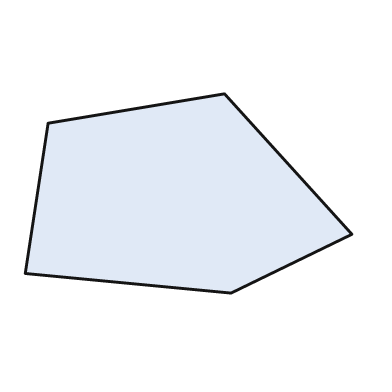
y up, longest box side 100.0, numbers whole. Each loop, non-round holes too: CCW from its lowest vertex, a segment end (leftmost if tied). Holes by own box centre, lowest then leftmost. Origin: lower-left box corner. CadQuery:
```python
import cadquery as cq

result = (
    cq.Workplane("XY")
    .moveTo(63.0, 0.0)
    .lineTo(100.0, 18.0)
    .lineTo(61.0, 61.0)
    .lineTo(7.0, 52.0)
    .lineTo(0.0, 6.0)
    .close()
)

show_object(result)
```